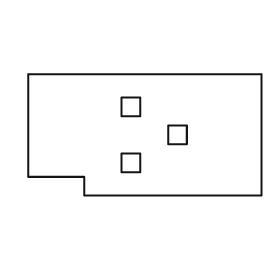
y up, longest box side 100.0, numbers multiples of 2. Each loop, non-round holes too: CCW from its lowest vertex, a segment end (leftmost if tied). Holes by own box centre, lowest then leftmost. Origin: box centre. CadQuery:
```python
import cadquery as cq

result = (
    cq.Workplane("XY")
    .moveTo(-26.0, -26.0)
    .lineTo(50.0, -26.0)
    .lineTo(50.0, 26.0)
    .lineTo(-50.0, 26.0)
    .lineTo(-50.0, -18.0)
    .lineTo(-26.0, -18.0)
    .close()
    .moveTo(-10.0, -16.0)
    .lineTo(-2.0, -16.0)
    .lineTo(-2.0, -8.0)
    .lineTo(-10.0, -8.0)
    .close()
    .moveTo(10.0, -4.0)
    .lineTo(18.0, -4.0)
    .lineTo(18.0, 4.0)
    .lineTo(10.0, 4.0)
    .close()
    .moveTo(-10.0, 8.0)
    .lineTo(-2.0, 8.0)
    .lineTo(-2.0, 16.0)
    .lineTo(-10.0, 16.0)
    .close()
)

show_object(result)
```